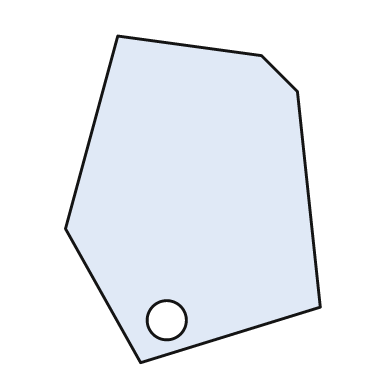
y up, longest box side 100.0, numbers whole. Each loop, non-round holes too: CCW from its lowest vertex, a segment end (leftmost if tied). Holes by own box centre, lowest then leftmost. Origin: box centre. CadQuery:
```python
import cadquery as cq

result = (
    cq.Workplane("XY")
    .moveTo(-16.0, -50.0)
    .lineTo(39.0, -33.0)
    .lineTo(32.0, 33.0)
    .lineTo(21.0, 44.0)
    .lineTo(-23.0, 50.0)
    .lineTo(-39.0, -9.0)
    .close()
    .moveTo(-8.0, -37.0)
    .circle(6.0)
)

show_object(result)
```